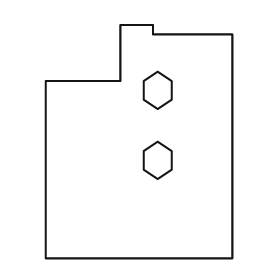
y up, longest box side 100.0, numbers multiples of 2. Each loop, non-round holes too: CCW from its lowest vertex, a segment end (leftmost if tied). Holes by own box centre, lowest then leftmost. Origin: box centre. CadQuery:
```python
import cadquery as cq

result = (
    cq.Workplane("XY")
    .moveTo(-40.0, -50.0)
    .lineTo(40.0, -50.0)
    .lineTo(40.0, 46.0)
    .lineTo(6.0, 46.0)
    .lineTo(6.0, 50.0)
    .lineTo(-8.0, 50.0)
    .lineTo(-8.0, 26.0)
    .lineTo(-40.0, 26.0)
    .close()
    .moveTo(8.0, -16.0)
    .lineTo(14.0, -12.0)
    .lineTo(14.0, -4.0)
    .lineTo(8.0, 0.0)
    .lineTo(2.0, -4.0)
    .lineTo(2.0, -12.0)
    .close()
    .moveTo(8.0, 14.0)
    .lineTo(14.0, 18.0)
    .lineTo(14.0, 26.0)
    .lineTo(8.0, 30.0)
    .lineTo(2.0, 26.0)
    .lineTo(2.0, 18.0)
    .close()
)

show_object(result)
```